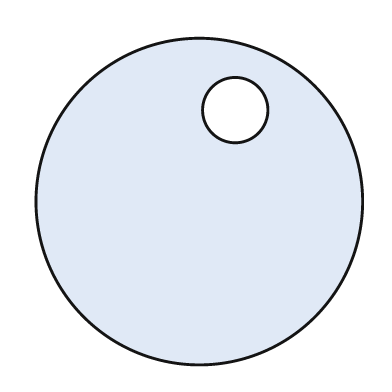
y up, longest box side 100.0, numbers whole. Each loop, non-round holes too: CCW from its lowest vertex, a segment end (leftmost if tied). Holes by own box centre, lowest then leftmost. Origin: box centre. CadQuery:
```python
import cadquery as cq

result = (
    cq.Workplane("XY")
    .moveTo(0.0, 0.0)
    .circle(50.0)
    .moveTo(11.0, 28.0)
    .circle(10.0)
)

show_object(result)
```